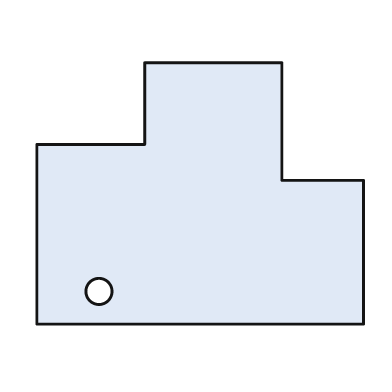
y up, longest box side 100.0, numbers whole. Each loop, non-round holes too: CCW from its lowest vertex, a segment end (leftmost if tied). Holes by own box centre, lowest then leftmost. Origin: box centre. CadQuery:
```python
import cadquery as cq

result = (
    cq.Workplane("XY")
    .moveTo(-50.0, -40.0)
    .lineTo(50.0, -40.0)
    .lineTo(50.0, 4.0)
    .lineTo(25.0, 4.0)
    .lineTo(25.0, 40.0)
    .lineTo(-17.0, 40.0)
    .lineTo(-17.0, 15.0)
    .lineTo(-50.0, 15.0)
    .close()
    .moveTo(-31.0, -30.0)
    .circle(4.0)
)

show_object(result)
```